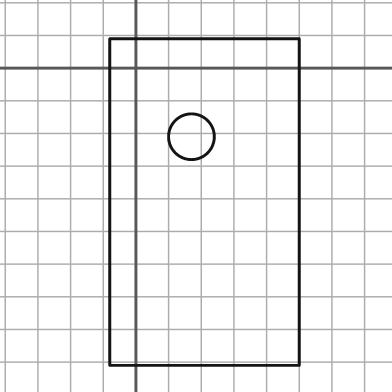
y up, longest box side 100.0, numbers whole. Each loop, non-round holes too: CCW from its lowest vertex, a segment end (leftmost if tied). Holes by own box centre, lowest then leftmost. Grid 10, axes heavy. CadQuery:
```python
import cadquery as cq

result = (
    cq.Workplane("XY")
    .moveTo(-8.0, -91.0)
    .lineTo(50.0, -91.0)
    .lineTo(50.0, 9.0)
    .lineTo(-8.0, 9.0)
    .close()
    .moveTo(17.0, -21.0)
    .circle(7.0)
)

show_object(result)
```